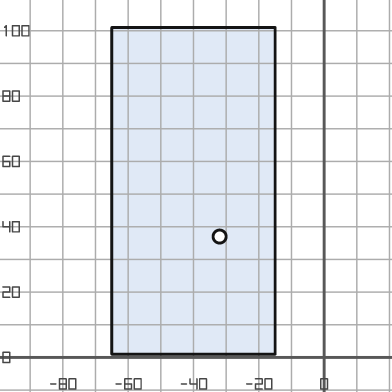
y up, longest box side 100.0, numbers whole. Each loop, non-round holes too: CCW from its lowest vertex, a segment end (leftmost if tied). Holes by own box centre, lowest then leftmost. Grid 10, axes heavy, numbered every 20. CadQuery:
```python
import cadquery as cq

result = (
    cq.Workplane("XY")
    .moveTo(-65.0, 1.0)
    .lineTo(-15.0, 1.0)
    .lineTo(-15.0, 101.0)
    .lineTo(-65.0, 101.0)
    .close()
    .moveTo(-32.0, 37.0)
    .circle(2.0)
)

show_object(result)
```